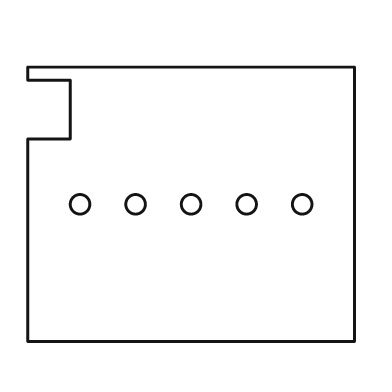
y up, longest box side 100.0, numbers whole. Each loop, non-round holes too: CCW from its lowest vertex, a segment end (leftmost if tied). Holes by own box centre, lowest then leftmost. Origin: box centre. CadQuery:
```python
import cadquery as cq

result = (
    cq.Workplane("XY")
    .moveTo(-50.0, -42.0)
    .lineTo(50.0, -42.0)
    .lineTo(50.0, 42.0)
    .lineTo(-50.0, 42.0)
    .lineTo(-50.0, 38.0)
    .lineTo(-37.0, 38.0)
    .lineTo(-37.0, 20.0)
    .lineTo(-50.0, 20.0)
    .close()
    .moveTo(-34.0, 0.0)
    .circle(3.0)
    .moveTo(-17.0, 0.0)
    .circle(3.0)
    .moveTo(0.0, 0.0)
    .circle(3.0)
    .moveTo(17.0, 0.0)
    .circle(3.0)
    .moveTo(34.0, 0.0)
    .circle(3.0)
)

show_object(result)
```